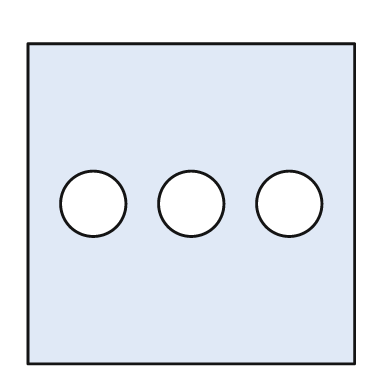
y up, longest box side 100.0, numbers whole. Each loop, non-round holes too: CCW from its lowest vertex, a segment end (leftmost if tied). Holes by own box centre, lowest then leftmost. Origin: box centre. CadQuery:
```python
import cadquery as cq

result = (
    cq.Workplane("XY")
    .moveTo(-50.0, -49.0)
    .lineTo(50.0, -49.0)
    .lineTo(50.0, 49.0)
    .lineTo(-50.0, 49.0)
    .close()
    .moveTo(-30.0, 0.0)
    .circle(10.0)
    .moveTo(0.0, 0.0)
    .circle(10.0)
    .moveTo(30.0, 0.0)
    .circle(10.0)
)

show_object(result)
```